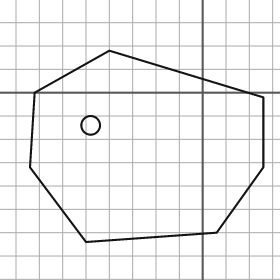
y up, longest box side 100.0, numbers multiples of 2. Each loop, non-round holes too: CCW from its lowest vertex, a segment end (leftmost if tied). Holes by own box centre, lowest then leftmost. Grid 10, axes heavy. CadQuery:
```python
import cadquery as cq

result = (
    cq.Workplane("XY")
    .moveTo(-50.0, -64.0)
    .lineTo(6.0, -60.0)
    .lineTo(26.0, -32.0)
    .lineTo(26.0, -2.0)
    .lineTo(-40.0, 18.0)
    .lineTo(-72.0, 0.0)
    .lineTo(-74.0, -32.0)
    .close()
    .moveTo(-48.0, -14.0)
    .circle(4.0)
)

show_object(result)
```